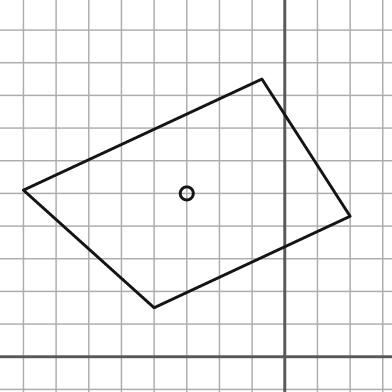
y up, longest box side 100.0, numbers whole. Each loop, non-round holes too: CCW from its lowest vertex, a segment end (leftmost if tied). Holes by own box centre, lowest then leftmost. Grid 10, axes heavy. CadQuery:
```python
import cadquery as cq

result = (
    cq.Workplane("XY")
    .moveTo(-40.0, 15.0)
    .lineTo(20.0, 43.0)
    .lineTo(-7.0, 85.0)
    .lineTo(-80.0, 51.0)
    .close()
    .moveTo(-30.0, 50.0)
    .circle(2.0)
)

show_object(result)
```